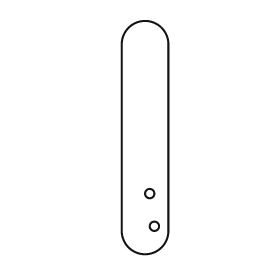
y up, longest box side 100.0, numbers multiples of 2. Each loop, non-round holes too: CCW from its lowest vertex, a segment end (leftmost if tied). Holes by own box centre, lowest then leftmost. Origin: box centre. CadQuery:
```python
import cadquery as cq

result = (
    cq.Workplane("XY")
    .moveTo(-10.0, -40.0)
    .threePointArc((0.0, -50.0), (10.0, -40.0))
    .lineTo(10.0, 40.0)
    .threePointArc((0.0, 50.0), (-10.0, 40.0))
    .close()
    .moveTo(4.0, -38.0)
    .circle(2.0)
    .moveTo(2.0, -24.0)
    .circle(2.0)
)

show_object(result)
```